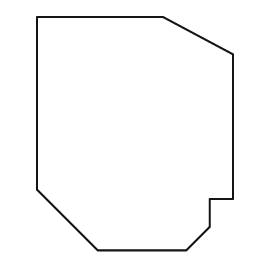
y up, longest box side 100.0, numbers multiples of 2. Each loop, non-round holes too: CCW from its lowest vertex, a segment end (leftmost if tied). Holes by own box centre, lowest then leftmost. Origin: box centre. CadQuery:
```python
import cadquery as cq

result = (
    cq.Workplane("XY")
    .moveTo(-16.0, -50.0)
    .lineTo(22.0, -50.0)
    .lineTo(32.0, -40.0)
    .lineTo(32.0, -28.0)
    .lineTo(42.0, -28.0)
    .lineTo(42.0, 34.0)
    .lineTo(12.0, 50.0)
    .lineTo(-42.0, 50.0)
    .lineTo(-42.0, -24.0)
    .close()
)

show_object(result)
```